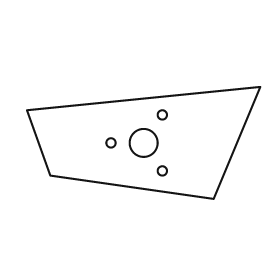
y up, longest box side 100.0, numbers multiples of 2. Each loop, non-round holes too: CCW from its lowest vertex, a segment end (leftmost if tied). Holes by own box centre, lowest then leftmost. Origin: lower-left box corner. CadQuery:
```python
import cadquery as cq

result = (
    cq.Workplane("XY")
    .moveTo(80.0, 0.0)
    .lineTo(100.0, 48.0)
    .lineTo(0.0, 38.0)
    .lineTo(10.0, 10.0)
    .close()
    .moveTo(58.0, 12.0)
    .circle(2.0)
    .moveTo(36.0, 24.0)
    .circle(2.0)
    .moveTo(50.0, 24.0)
    .circle(6.0)
    .moveTo(58.0, 36.0)
    .circle(2.0)
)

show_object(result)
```